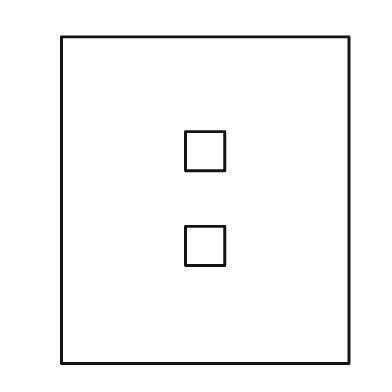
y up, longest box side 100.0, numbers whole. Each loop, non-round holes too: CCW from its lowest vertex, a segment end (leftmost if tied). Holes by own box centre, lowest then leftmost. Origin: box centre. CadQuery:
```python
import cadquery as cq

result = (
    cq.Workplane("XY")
    .moveTo(-44.0, -50.0)
    .lineTo(44.0, -50.0)
    .lineTo(44.0, 50.0)
    .lineTo(-44.0, 50.0)
    .close()
    .moveTo(-6.0, -20.0)
    .lineTo(6.0, -20.0)
    .lineTo(6.0, -8.0)
    .lineTo(-6.0, -8.0)
    .close()
    .moveTo(-6.0, 9.0)
    .lineTo(6.0, 9.0)
    .lineTo(6.0, 21.0)
    .lineTo(-6.0, 21.0)
    .close()
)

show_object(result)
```